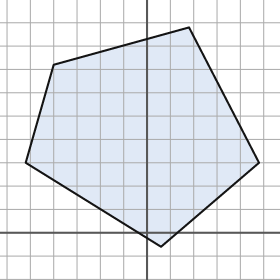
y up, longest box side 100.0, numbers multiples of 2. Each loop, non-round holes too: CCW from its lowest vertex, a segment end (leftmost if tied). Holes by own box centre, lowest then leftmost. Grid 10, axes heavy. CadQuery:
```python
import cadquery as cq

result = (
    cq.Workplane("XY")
    .moveTo(6.0, -6.0)
    .lineTo(48.0, 30.0)
    .lineTo(18.0, 88.0)
    .lineTo(-40.0, 72.0)
    .lineTo(-52.0, 30.0)
    .close()
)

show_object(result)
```